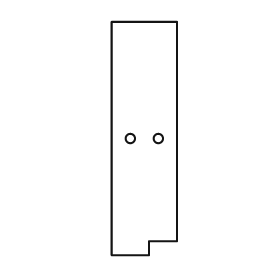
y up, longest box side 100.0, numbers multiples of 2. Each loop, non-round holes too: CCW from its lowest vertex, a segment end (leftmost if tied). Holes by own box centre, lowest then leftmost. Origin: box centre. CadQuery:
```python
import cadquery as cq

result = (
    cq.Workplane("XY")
    .moveTo(-14.0, -50.0)
    .lineTo(2.0, -50.0)
    .lineTo(2.0, -44.0)
    .lineTo(14.0, -44.0)
    .lineTo(14.0, 50.0)
    .lineTo(-14.0, 50.0)
    .close()
    .moveTo(-6.0, 0.0)
    .circle(2.0)
    .moveTo(6.0, 0.0)
    .circle(2.0)
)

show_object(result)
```